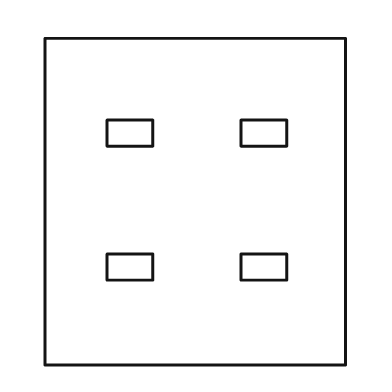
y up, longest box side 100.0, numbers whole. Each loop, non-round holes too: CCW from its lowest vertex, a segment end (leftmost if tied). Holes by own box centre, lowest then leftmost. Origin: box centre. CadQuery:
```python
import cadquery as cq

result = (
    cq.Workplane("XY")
    .moveTo(-46.0, -50.0)
    .lineTo(46.0, -50.0)
    .lineTo(46.0, 50.0)
    .lineTo(-46.0, 50.0)
    .close()
    .moveTo(-27.0, -24.0)
    .lineTo(-13.0, -24.0)
    .lineTo(-13.0, -16.0)
    .lineTo(-27.0, -16.0)
    .close()
    .moveTo(14.0, -24.0)
    .lineTo(28.0, -24.0)
    .lineTo(28.0, -16.0)
    .lineTo(14.0, -16.0)
    .close()
    .moveTo(-27.0, 17.0)
    .lineTo(-13.0, 17.0)
    .lineTo(-13.0, 25.0)
    .lineTo(-27.0, 25.0)
    .close()
    .moveTo(14.0, 17.0)
    .lineTo(28.0, 17.0)
    .lineTo(28.0, 25.0)
    .lineTo(14.0, 25.0)
    .close()
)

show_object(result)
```